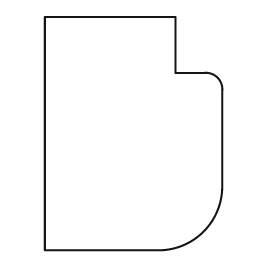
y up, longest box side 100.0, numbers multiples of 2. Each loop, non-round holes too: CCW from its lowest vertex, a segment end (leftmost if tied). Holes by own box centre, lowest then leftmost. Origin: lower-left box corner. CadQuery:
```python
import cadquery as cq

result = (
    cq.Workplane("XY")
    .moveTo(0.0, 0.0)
    .lineTo(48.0, 0.0)
    .threePointArc((68.0, 8.0), (76.0, 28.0))
    .lineTo(76.0, 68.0)
    .threePointArc((74.0, 74.0), (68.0, 76.0))
    .lineTo(56.0, 76.0)
    .lineTo(56.0, 100.0)
    .lineTo(0.0, 100.0)
    .close()
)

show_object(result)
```